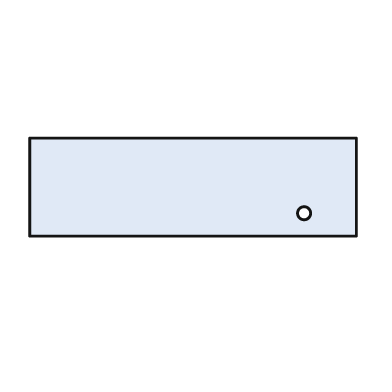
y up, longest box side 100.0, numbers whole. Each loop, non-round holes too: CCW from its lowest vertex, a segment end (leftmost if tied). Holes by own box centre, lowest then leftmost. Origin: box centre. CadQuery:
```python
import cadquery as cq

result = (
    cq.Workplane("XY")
    .moveTo(-50.0, -15.0)
    .lineTo(50.0, -15.0)
    .lineTo(50.0, 15.0)
    .lineTo(-50.0, 15.0)
    .close()
    .moveTo(34.0, -8.0)
    .circle(2.0)
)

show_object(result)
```